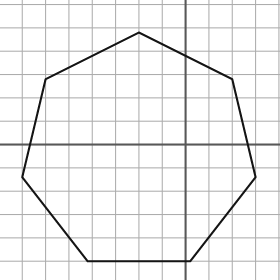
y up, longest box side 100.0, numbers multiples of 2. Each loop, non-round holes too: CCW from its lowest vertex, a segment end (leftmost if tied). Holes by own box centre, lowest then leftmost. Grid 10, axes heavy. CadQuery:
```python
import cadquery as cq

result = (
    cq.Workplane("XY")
    .moveTo(-42.0, -50.0)
    .lineTo(2.0, -50.0)
    .lineTo(30.0, -14.0)
    .lineTo(20.0, 28.0)
    .lineTo(-20.0, 48.0)
    .lineTo(-60.0, 28.0)
    .lineTo(-70.0, -14.0)
    .close()
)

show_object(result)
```